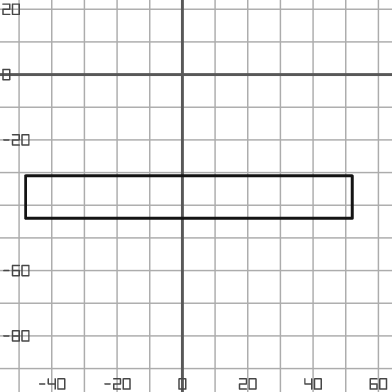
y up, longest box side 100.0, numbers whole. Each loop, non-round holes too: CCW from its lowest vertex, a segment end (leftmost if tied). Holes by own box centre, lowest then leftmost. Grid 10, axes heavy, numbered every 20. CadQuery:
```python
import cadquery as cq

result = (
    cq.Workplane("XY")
    .moveTo(-48.0, -44.0)
    .lineTo(52.0, -44.0)
    .lineTo(52.0, -31.0)
    .lineTo(-48.0, -31.0)
    .close()
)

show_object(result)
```